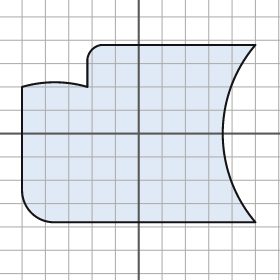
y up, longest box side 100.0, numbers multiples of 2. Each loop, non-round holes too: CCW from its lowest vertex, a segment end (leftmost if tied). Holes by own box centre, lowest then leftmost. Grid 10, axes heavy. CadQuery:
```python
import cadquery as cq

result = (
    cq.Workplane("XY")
    .moveTo(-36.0, -38.0)
    .lineTo(50.0, -38.0)
    .threePointArc((36.0, 0.0), (50.0, 38.0))
    .lineTo(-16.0, 38.0)
    .threePointArc((-20.0, 36.0), (-22.0, 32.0))
    .lineTo(-22.0, 20.0)
    .threePointArc((-36.0, 22.0), (-50.0, 20.0))
    .lineTo(-50.0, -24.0)
    .threePointArc((-46.0, -34.0), (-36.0, -38.0))
    .close()
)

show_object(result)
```